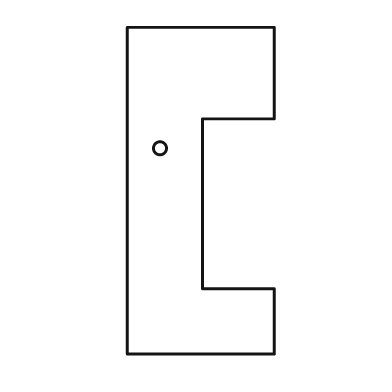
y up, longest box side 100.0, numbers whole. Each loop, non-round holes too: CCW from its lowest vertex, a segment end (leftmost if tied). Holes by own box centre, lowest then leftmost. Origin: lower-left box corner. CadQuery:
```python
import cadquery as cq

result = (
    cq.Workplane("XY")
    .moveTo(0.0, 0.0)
    .lineTo(45.0, 0.0)
    .lineTo(45.0, 20.0)
    .lineTo(23.0, 20.0)
    .lineTo(23.0, 72.0)
    .lineTo(45.0, 72.0)
    .lineTo(45.0, 100.0)
    .lineTo(0.0, 100.0)
    .close()
    .moveTo(10.0, 63.0)
    .circle(2.0)
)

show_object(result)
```